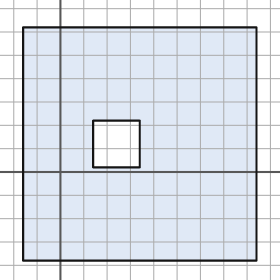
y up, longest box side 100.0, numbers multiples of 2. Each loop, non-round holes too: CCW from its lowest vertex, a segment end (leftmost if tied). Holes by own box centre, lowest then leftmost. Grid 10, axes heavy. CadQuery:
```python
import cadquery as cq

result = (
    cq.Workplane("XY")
    .moveTo(-16.0, -38.0)
    .lineTo(84.0, -38.0)
    .lineTo(84.0, 62.0)
    .lineTo(-16.0, 62.0)
    .close()
    .moveTo(14.0, 2.0)
    .lineTo(34.0, 2.0)
    .lineTo(34.0, 22.0)
    .lineTo(14.0, 22.0)
    .close()
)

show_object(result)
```